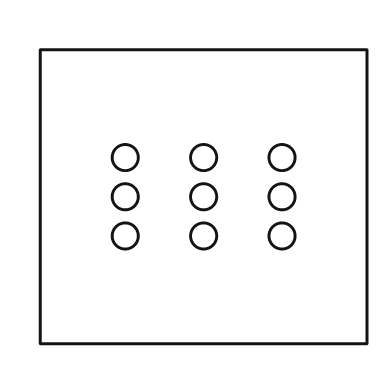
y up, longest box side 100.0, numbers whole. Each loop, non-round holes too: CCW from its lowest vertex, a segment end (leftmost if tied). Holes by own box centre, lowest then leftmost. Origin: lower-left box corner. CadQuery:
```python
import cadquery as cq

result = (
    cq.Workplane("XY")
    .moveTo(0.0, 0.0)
    .lineTo(100.0, 0.0)
    .lineTo(100.0, 90.0)
    .lineTo(0.0, 90.0)
    .close()
    .moveTo(26.0, 33.0)
    .circle(4.0)
    .moveTo(50.0, 33.0)
    .circle(4.0)
    .moveTo(74.0, 33.0)
    .circle(4.0)
    .moveTo(26.0, 45.0)
    .circle(4.0)
    .moveTo(50.0, 45.0)
    .circle(4.0)
    .moveTo(74.0, 45.0)
    .circle(4.0)
    .moveTo(26.0, 57.0)
    .circle(4.0)
    .moveTo(50.0, 57.0)
    .circle(4.0)
    .moveTo(74.0, 57.0)
    .circle(4.0)
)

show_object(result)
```